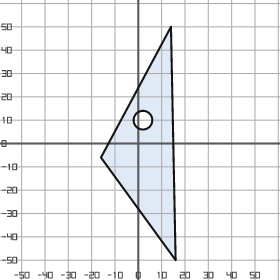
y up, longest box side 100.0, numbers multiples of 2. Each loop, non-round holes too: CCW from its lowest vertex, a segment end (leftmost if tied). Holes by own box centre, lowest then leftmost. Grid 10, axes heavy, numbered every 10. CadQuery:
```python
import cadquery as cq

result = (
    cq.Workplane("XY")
    .moveTo(16.0, -50.0)
    .lineTo(14.0, 50.0)
    .lineTo(-16.0, -6.0)
    .close()
    .moveTo(2.0, 10.0)
    .circle(4.0)
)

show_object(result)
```